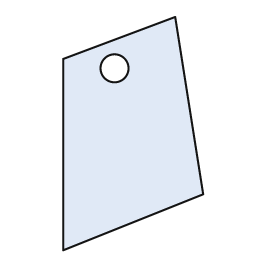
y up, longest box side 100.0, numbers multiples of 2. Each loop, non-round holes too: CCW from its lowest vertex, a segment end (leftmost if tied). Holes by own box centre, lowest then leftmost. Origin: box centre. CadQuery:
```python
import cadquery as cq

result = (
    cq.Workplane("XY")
    .moveTo(-30.0, -50.0)
    .lineTo(30.0, -26.0)
    .lineTo(18.0, 50.0)
    .lineTo(-30.0, 32.0)
    .close()
    .moveTo(-8.0, 28.0)
    .circle(6.0)
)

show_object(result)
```